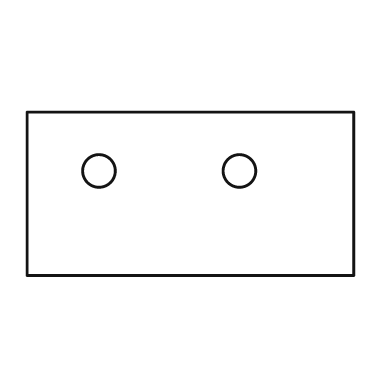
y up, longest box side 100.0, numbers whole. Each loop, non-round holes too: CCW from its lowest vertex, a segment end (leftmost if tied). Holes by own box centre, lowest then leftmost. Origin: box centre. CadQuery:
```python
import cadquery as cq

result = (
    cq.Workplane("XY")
    .moveTo(-50.0, -25.0)
    .lineTo(50.0, -25.0)
    .lineTo(50.0, 25.0)
    .lineTo(-50.0, 25.0)
    .close()
    .moveTo(-28.0, 7.0)
    .circle(5.0)
    .moveTo(15.0, 7.0)
    .circle(5.0)
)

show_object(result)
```